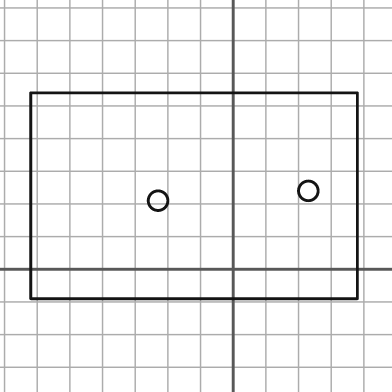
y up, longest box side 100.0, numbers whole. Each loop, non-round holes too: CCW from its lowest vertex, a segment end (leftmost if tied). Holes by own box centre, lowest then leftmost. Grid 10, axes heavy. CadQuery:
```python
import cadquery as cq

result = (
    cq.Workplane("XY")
    .moveTo(-62.0, -9.0)
    .lineTo(38.0, -9.0)
    .lineTo(38.0, 54.0)
    .lineTo(-62.0, 54.0)
    .close()
    .moveTo(-23.0, 21.0)
    .circle(3.0)
    .moveTo(23.0, 24.0)
    .circle(3.0)
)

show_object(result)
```